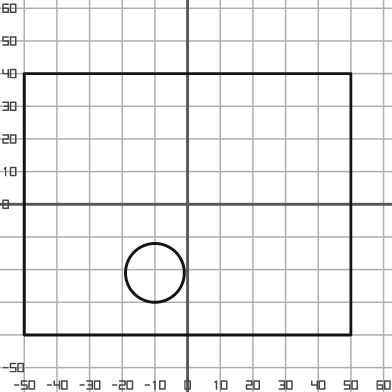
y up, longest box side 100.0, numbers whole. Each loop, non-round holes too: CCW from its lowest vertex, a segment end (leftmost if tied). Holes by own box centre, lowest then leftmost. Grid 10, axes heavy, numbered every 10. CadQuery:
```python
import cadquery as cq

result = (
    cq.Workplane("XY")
    .moveTo(-50.0, -40.0)
    .lineTo(50.0, -40.0)
    .lineTo(50.0, 40.0)
    .lineTo(-50.0, 40.0)
    .close()
    .moveTo(-10.0, -21.0)
    .circle(9.0)
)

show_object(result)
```